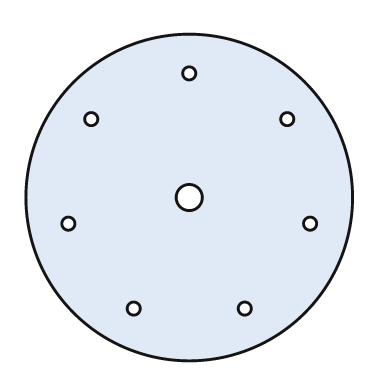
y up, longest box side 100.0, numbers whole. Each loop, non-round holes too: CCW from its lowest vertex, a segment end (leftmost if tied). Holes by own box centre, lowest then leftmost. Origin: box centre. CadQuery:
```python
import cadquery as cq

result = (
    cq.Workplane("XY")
    .moveTo(0.0, 0.0)
    .circle(50.0)
    .moveTo(-17.0, -34.0)
    .circle(2.0)
    .moveTo(17.0, -34.0)
    .circle(2.0)
    .moveTo(-37.0, -8.0)
    .circle(2.0)
    .moveTo(37.0, -8.0)
    .circle(2.0)
    .moveTo(0.0, 0.0)
    .circle(4.0)
    .moveTo(-30.0, 24.0)
    .circle(2.0)
    .moveTo(30.0, 24.0)
    .circle(2.0)
    .moveTo(0.0, 38.0)
    .circle(2.0)
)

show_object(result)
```